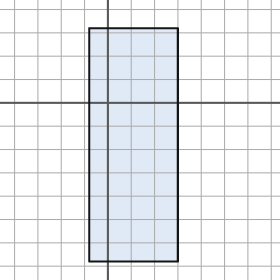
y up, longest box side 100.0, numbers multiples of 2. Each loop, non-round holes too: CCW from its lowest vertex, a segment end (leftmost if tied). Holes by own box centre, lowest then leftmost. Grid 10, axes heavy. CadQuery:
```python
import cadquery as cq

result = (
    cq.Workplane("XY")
    .moveTo(-8.0, -68.0)
    .lineTo(30.0, -68.0)
    .lineTo(30.0, 32.0)
    .lineTo(-8.0, 32.0)
    .close()
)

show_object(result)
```